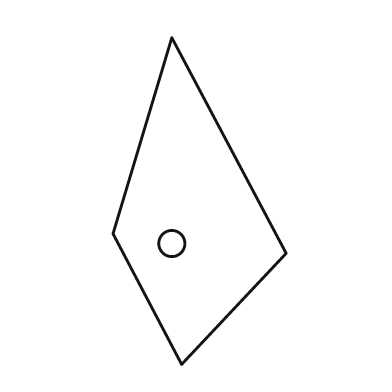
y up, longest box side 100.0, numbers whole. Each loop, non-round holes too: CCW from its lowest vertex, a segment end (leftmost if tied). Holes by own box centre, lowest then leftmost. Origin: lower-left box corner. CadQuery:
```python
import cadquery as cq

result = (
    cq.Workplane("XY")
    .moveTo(21.0, 0.0)
    .lineTo(53.0, 34.0)
    .lineTo(18.0, 100.0)
    .lineTo(0.0, 40.0)
    .close()
    .moveTo(18.0, 37.0)
    .circle(4.0)
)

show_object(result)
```